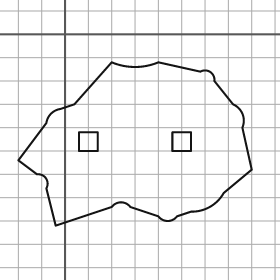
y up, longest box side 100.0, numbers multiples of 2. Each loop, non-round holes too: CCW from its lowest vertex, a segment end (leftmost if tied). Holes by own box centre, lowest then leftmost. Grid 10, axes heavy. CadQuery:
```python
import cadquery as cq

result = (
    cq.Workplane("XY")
    .moveTo(-4.0, -82.0)
    .lineTo(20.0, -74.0)
    .threePointArc((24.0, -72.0), (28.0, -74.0))
    .lineTo(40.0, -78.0)
    .threePointArc((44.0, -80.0), (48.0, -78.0))
    .lineTo(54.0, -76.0)
    .threePointArc((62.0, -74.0), (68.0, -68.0))
    .lineTo(80.0, -58.0)
    .lineTo(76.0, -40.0)
    .threePointArc((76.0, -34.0), (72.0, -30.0))
    .lineTo(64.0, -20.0)
    .threePointArc((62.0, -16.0), (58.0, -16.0))
    .lineTo(40.0, -12.0)
    .threePointArc((30.0, -14.0), (20.0, -12.0))
    .lineTo(4.0, -30.0)
    .lineTo(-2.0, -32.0)
    .threePointArc((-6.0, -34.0), (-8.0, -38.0))
    .lineTo(-20.0, -54.0)
    .lineTo(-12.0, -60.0)
    .threePointArc((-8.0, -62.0), (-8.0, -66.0))
    .close()
    .moveTo(6.0, -50.0)
    .lineTo(14.0, -50.0)
    .lineTo(14.0, -42.0)
    .lineTo(6.0, -42.0)
    .close()
    .moveTo(46.0, -50.0)
    .lineTo(54.0, -50.0)
    .lineTo(54.0, -42.0)
    .lineTo(46.0, -42.0)
    .close()
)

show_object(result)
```